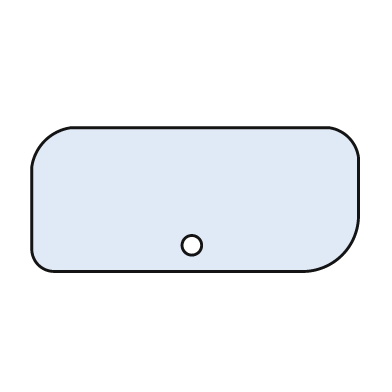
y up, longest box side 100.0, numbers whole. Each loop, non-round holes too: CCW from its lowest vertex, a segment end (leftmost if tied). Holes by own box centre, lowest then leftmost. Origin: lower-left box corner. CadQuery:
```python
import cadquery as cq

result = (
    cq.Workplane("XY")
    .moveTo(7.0, 0.0)
    .lineTo(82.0, 0.0)
    .threePointArc((95.0, 5.0), (100.0, 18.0))
    .lineTo(100.0, 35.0)
    .threePointArc((97.0, 41.0), (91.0, 44.0))
    .lineTo(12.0, 44.0)
    .threePointArc((4.0, 40.0), (0.0, 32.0))
    .lineTo(0.0, 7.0)
    .threePointArc((2.0, 2.0), (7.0, 0.0))
    .close()
    .moveTo(49.0, 8.0)
    .circle(3.0)
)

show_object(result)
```